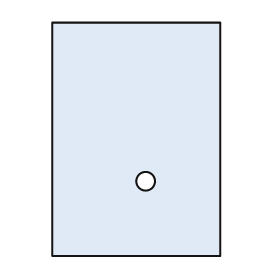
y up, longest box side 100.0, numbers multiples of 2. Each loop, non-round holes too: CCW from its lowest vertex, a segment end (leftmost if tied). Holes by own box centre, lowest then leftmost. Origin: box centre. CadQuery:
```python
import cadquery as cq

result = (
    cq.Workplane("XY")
    .moveTo(-36.0, -50.0)
    .lineTo(36.0, -50.0)
    .lineTo(36.0, 50.0)
    .lineTo(-36.0, 50.0)
    .close()
    .moveTo(4.0, -18.0)
    .circle(4.0)
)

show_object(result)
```